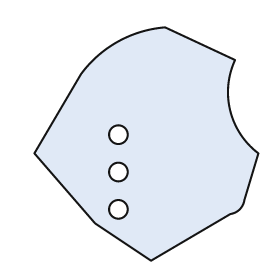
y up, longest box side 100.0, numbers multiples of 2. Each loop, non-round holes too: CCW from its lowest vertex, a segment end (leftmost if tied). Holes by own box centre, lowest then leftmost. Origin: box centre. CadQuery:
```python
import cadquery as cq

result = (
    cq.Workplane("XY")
    .moveTo(2.0, -50.0)
    .lineTo(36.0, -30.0)
    .threePointArc((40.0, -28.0), (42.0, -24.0))
    .lineTo(48.0, -4.0)
    .threePointArc((36.0, 14.0), (38.0, 36.0))
    .lineTo(8.0, 50.0)
    .threePointArc((-12.0, 44.0), (-28.0, 30.0))
    .lineTo(-48.0, -4.0)
    .lineTo(-22.0, -34.0)
    .close()
    .moveTo(-12.0, -28.0)
    .circle(4.0)
    .moveTo(-12.0, -12.0)
    .circle(4.0)
    .moveTo(-12.0, 4.0)
    .circle(4.0)
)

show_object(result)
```